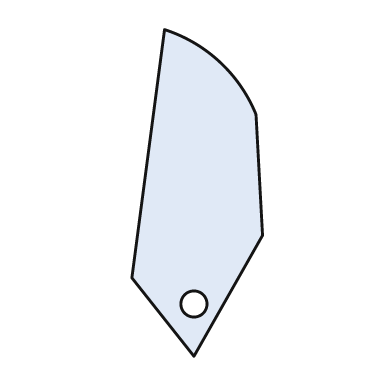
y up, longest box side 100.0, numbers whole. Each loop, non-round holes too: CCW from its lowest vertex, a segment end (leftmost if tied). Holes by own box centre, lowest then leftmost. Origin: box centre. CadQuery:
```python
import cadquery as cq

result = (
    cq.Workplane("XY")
    .moveTo(-1.0, -50.0)
    .lineTo(20.0, -13.0)
    .lineTo(18.0, 24.0)
    .threePointArc((7.0, 40.0), (-10.0, 50.0))
    .lineTo(-20.0, -26.0)
    .close()
    .moveTo(-1.0, -34.0)
    .circle(4.0)
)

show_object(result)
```